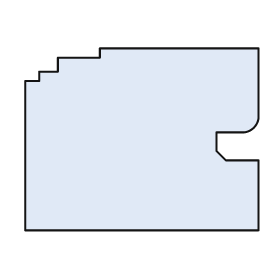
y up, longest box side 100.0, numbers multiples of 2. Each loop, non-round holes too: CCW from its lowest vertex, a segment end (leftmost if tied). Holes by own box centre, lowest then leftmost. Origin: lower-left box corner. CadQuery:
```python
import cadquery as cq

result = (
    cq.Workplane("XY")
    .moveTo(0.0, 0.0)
    .lineTo(100.0, 0.0)
    .lineTo(100.0, 30.0)
    .lineTo(86.0, 30.0)
    .lineTo(82.0, 34.0)
    .lineTo(82.0, 42.0)
    .lineTo(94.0, 42.0)
    .threePointArc((98.0, 44.0), (100.0, 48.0))
    .lineTo(100.0, 78.0)
    .lineTo(32.0, 78.0)
    .lineTo(32.0, 74.0)
    .lineTo(14.0, 74.0)
    .lineTo(14.0, 68.0)
    .lineTo(6.0, 68.0)
    .lineTo(6.0, 64.0)
    .lineTo(0.0, 64.0)
    .close()
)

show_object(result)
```